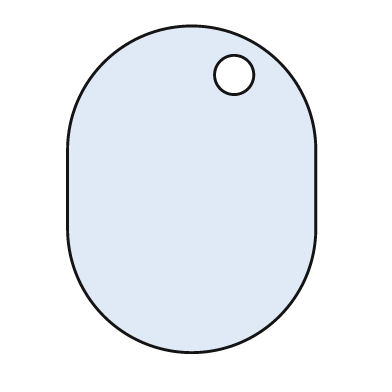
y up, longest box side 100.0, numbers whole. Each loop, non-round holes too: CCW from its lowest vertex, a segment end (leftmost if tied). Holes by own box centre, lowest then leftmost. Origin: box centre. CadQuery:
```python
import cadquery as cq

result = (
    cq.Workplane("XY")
    .moveTo(-38.0, -12.0)
    .threePointArc((0.0, -50.0), (38.0, -12.0))
    .lineTo(38.0, 12.0)
    .threePointArc((0.0, 50.0), (-38.0, 12.0))
    .close()
    .moveTo(13.0, 35.0)
    .circle(6.0)
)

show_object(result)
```